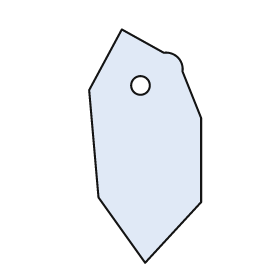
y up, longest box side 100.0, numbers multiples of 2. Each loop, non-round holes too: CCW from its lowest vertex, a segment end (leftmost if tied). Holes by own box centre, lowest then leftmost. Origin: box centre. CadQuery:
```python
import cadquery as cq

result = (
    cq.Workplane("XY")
    .moveTo(0.0, -50.0)
    .lineTo(24.0, -24.0)
    .lineTo(24.0, 12.0)
    .lineTo(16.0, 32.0)
    .threePointArc((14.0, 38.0), (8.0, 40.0))
    .lineTo(-10.0, 50.0)
    .lineTo(-24.0, 24.0)
    .lineTo(-20.0, -22.0)
    .close()
    .moveTo(-2.0, 26.0)
    .circle(4.0)
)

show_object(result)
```